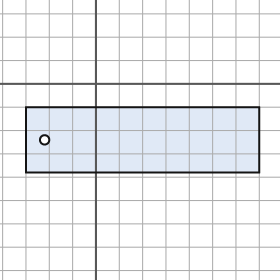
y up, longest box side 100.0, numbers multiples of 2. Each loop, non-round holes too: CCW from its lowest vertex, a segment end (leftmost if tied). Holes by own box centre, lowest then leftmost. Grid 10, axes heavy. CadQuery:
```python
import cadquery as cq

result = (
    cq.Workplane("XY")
    .moveTo(-30.0, -38.0)
    .lineTo(70.0, -38.0)
    .lineTo(70.0, -10.0)
    .lineTo(-30.0, -10.0)
    .close()
    .moveTo(-22.0, -24.0)
    .circle(2.0)
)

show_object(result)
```